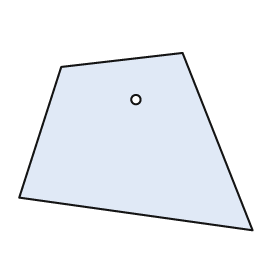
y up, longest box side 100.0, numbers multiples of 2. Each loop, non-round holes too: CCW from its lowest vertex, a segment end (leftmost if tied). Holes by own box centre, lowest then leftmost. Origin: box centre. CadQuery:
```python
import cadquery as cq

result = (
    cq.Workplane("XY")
    .moveTo(50.0, -38.0)
    .lineTo(20.0, 38.0)
    .lineTo(-32.0, 32.0)
    .lineTo(-50.0, -24.0)
    .close()
    .moveTo(0.0, 18.0)
    .circle(2.0)
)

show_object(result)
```